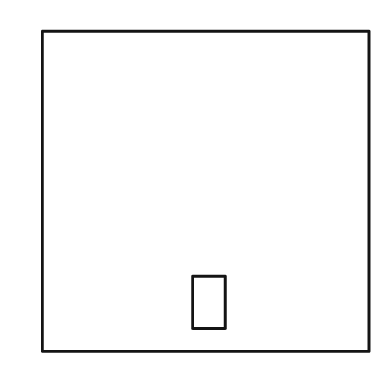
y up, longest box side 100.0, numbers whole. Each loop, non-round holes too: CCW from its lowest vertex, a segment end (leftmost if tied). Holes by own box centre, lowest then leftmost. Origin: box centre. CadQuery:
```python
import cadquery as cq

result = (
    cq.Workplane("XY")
    .moveTo(-50.0, -49.0)
    .lineTo(50.0, -49.0)
    .lineTo(50.0, 49.0)
    .lineTo(-50.0, 49.0)
    .close()
    .moveTo(-4.0, -42.0)
    .lineTo(6.0, -42.0)
    .lineTo(6.0, -26.0)
    .lineTo(-4.0, -26.0)
    .close()
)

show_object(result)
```